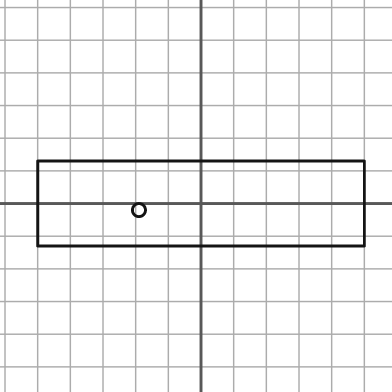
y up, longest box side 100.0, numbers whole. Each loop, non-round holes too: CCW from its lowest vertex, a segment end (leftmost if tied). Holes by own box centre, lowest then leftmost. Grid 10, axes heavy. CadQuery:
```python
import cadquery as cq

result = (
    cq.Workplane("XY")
    .moveTo(-50.0, -13.0)
    .lineTo(50.0, -13.0)
    .lineTo(50.0, 13.0)
    .lineTo(-50.0, 13.0)
    .close()
    .moveTo(-19.0, -2.0)
    .circle(2.0)
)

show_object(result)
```